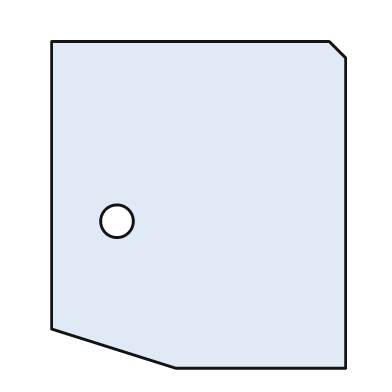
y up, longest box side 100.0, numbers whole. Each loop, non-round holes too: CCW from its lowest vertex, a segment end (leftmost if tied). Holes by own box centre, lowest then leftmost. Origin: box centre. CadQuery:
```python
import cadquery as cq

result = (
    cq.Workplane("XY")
    .moveTo(-7.0, -50.0)
    .lineTo(45.0, -50.0)
    .lineTo(45.0, 45.0)
    .lineTo(40.0, 50.0)
    .lineTo(-45.0, 50.0)
    .lineTo(-45.0, -38.0)
    .close()
    .moveTo(-25.0, -5.0)
    .circle(5.0)
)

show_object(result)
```